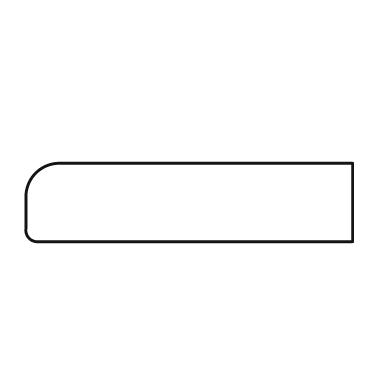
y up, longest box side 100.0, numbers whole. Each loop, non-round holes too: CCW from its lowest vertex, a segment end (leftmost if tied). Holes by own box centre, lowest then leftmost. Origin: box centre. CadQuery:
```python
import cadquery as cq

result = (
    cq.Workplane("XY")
    .moveTo(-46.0, -12.0)
    .lineTo(50.0, -12.0)
    .lineTo(50.0, 12.0)
    .lineTo(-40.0, 12.0)
    .threePointArc((-47.0, 9.0), (-50.0, 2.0))
    .lineTo(-50.0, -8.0)
    .threePointArc((-49.0, -11.0), (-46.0, -12.0))
    .close()
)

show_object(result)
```